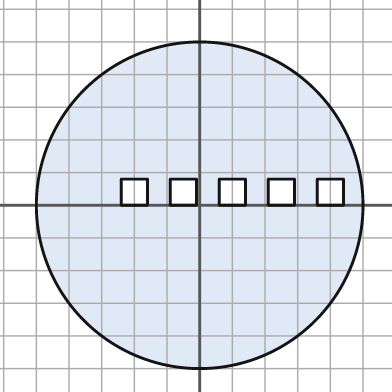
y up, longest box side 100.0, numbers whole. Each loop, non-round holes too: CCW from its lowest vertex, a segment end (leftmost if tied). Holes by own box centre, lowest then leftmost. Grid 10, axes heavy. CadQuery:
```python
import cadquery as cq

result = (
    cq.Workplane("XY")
    .moveTo(0.0, 0.0)
    .circle(50.0)
    .moveTo(-24.0, 0.0)
    .lineTo(-16.0, 0.0)
    .lineTo(-16.0, 8.0)
    .lineTo(-24.0, 8.0)
    .close()
    .moveTo(-9.0, 0.0)
    .lineTo(-1.0, 0.0)
    .lineTo(-1.0, 8.0)
    .lineTo(-9.0, 8.0)
    .close()
    .moveTo(6.0, 0.0)
    .lineTo(14.0, 0.0)
    .lineTo(14.0, 8.0)
    .lineTo(6.0, 8.0)
    .close()
    .moveTo(21.0, 0.0)
    .lineTo(29.0, 0.0)
    .lineTo(29.0, 8.0)
    .lineTo(21.0, 8.0)
    .close()
    .moveTo(36.0, 0.0)
    .lineTo(44.0, 0.0)
    .lineTo(44.0, 8.0)
    .lineTo(36.0, 8.0)
    .close()
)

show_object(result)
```